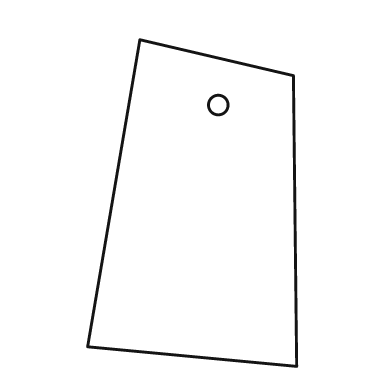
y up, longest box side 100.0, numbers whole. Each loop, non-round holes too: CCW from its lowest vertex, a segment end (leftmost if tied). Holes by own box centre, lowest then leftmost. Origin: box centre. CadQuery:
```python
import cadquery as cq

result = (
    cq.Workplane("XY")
    .moveTo(32.0, -50.0)
    .lineTo(31.0, 39.0)
    .lineTo(-16.0, 50.0)
    .lineTo(-32.0, -44.0)
    .close()
    .moveTo(8.0, 30.0)
    .circle(3.0)
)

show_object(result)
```